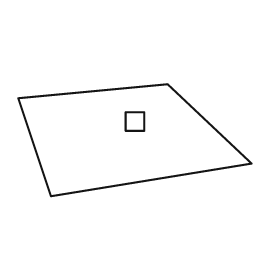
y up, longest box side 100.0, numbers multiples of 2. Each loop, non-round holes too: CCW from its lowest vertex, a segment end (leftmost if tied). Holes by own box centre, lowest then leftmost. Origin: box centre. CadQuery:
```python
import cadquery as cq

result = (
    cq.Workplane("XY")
    .moveTo(-36.0, -24.0)
    .lineTo(50.0, -10.0)
    .lineTo(14.0, 24.0)
    .lineTo(-50.0, 18.0)
    .close()
    .moveTo(-4.0, 4.0)
    .lineTo(4.0, 4.0)
    .lineTo(4.0, 12.0)
    .lineTo(-4.0, 12.0)
    .close()
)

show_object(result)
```